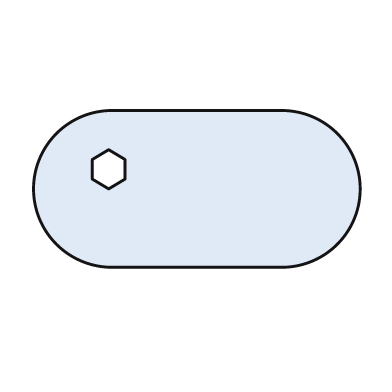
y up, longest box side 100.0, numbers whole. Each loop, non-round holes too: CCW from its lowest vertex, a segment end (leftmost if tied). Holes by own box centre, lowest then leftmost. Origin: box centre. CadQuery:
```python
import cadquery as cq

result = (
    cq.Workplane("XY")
    .moveTo(-26.0, -24.0)
    .lineTo(26.0, -24.0)
    .threePointArc((50.0, 0.0), (26.0, 24.0))
    .lineTo(-26.0, 24.0)
    .threePointArc((-50.0, 0.0), (-26.0, -24.0))
    .close()
    .moveTo(-27.0, 0.0)
    .lineTo(-22.0, 3.0)
    .lineTo(-22.0, 9.0)
    .lineTo(-27.0, 12.0)
    .lineTo(-32.0, 9.0)
    .lineTo(-32.0, 3.0)
    .close()
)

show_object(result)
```